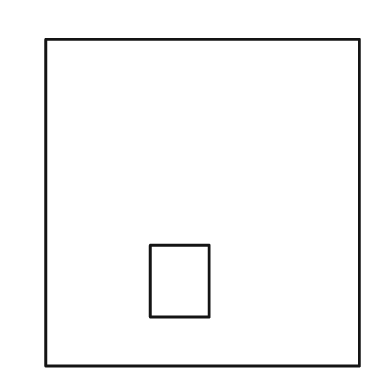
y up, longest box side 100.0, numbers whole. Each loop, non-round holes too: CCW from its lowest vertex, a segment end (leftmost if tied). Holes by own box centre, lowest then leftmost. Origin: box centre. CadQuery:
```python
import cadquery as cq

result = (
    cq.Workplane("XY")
    .moveTo(-48.0, -50.0)
    .lineTo(48.0, -50.0)
    .lineTo(48.0, 50.0)
    .lineTo(-48.0, 50.0)
    .close()
    .moveTo(-16.0, -35.0)
    .lineTo(2.0, -35.0)
    .lineTo(2.0, -13.0)
    .lineTo(-16.0, -13.0)
    .close()
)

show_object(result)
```